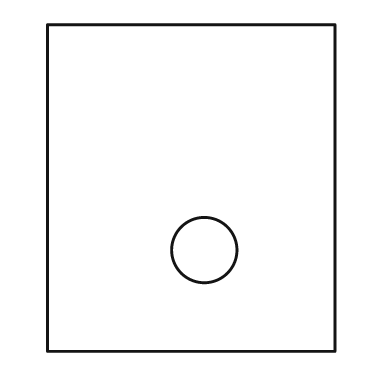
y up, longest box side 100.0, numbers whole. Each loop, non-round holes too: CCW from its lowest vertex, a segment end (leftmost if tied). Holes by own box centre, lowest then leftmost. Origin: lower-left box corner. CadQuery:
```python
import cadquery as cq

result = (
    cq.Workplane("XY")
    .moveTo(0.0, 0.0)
    .lineTo(88.0, 0.0)
    .lineTo(88.0, 100.0)
    .lineTo(0.0, 100.0)
    .close()
    .moveTo(48.0, 31.0)
    .circle(10.0)
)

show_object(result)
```